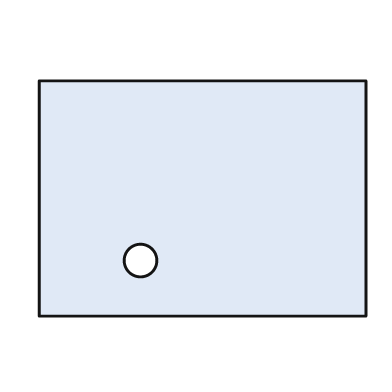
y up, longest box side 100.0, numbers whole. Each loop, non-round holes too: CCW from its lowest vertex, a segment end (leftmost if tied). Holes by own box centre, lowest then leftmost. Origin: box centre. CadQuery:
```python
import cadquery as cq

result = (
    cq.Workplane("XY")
    .moveTo(-50.0, -36.0)
    .lineTo(50.0, -36.0)
    .lineTo(50.0, 36.0)
    .lineTo(-50.0, 36.0)
    .close()
    .moveTo(-19.0, -19.0)
    .circle(5.0)
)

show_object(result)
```